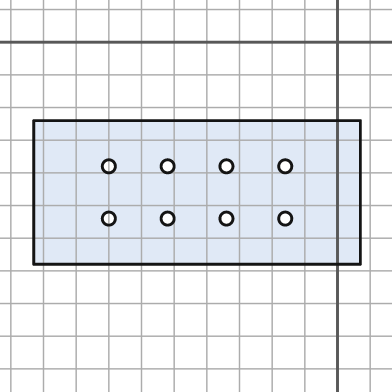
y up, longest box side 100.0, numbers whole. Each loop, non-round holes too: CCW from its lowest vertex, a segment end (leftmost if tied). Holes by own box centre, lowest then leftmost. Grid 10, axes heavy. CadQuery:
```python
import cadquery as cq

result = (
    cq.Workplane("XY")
    .moveTo(-93.0, -68.0)
    .lineTo(7.0, -68.0)
    .lineTo(7.0, -24.0)
    .lineTo(-93.0, -24.0)
    .close()
    .moveTo(-70.0, -54.0)
    .circle(2.0)
    .moveTo(-52.0, -54.0)
    .circle(2.0)
    .moveTo(-34.0, -54.0)
    .circle(2.0)
    .moveTo(-16.0, -54.0)
    .circle(2.0)
    .moveTo(-70.0, -38.0)
    .circle(2.0)
    .moveTo(-52.0, -38.0)
    .circle(2.0)
    .moveTo(-34.0, -38.0)
    .circle(2.0)
    .moveTo(-16.0, -38.0)
    .circle(2.0)
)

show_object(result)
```